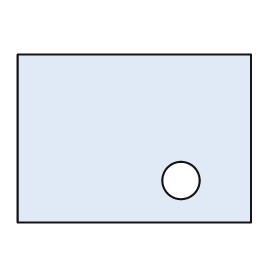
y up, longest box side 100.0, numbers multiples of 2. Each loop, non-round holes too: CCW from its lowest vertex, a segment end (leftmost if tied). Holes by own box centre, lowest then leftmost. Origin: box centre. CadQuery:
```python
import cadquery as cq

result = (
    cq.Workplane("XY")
    .moveTo(-50.0, -36.0)
    .lineTo(50.0, -36.0)
    .lineTo(50.0, 36.0)
    .lineTo(-50.0, 36.0)
    .close()
    .moveTo(20.0, -18.0)
    .circle(8.0)
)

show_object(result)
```